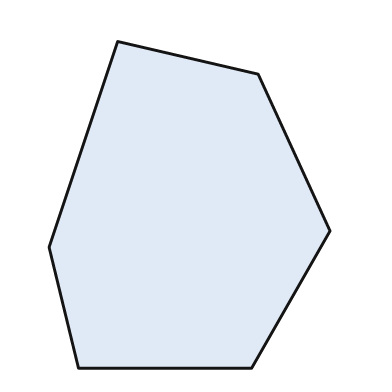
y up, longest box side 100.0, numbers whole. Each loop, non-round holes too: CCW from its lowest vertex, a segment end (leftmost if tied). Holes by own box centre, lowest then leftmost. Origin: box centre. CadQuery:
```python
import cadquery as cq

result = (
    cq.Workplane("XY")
    .moveTo(-34.0, -50.0)
    .lineTo(19.0, -50.0)
    .lineTo(43.0, -8.0)
    .lineTo(21.0, 40.0)
    .lineTo(-22.0, 50.0)
    .lineTo(-43.0, -13.0)
    .close()
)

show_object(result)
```